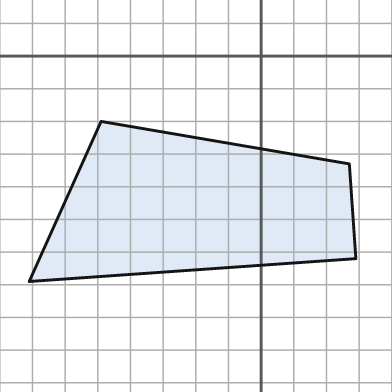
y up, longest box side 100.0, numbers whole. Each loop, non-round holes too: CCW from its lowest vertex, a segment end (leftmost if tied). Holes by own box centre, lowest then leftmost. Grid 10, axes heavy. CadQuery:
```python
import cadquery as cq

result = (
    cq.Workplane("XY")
    .moveTo(-71.0, -69.0)
    .lineTo(29.0, -62.0)
    .lineTo(27.0, -33.0)
    .lineTo(-49.0, -20.0)
    .close()
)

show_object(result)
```